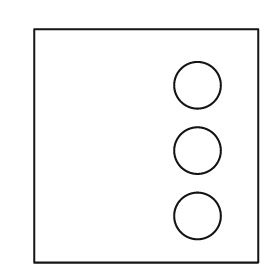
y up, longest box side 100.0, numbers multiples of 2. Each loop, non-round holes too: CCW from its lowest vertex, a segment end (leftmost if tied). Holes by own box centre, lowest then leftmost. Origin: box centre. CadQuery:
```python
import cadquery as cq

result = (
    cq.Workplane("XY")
    .moveTo(-48.0, -50.0)
    .lineTo(48.0, -50.0)
    .lineTo(48.0, 50.0)
    .lineTo(-48.0, 50.0)
    .close()
    .moveTo(22.0, -30.0)
    .circle(10.0)
    .moveTo(22.0, -2.0)
    .circle(10.0)
    .moveTo(22.0, 26.0)
    .circle(10.0)
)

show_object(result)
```